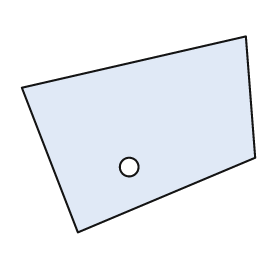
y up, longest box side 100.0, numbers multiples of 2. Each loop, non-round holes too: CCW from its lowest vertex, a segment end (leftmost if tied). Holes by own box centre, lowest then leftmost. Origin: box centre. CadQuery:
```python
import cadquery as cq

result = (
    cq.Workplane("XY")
    .moveTo(-26.0, -42.0)
    .lineTo(50.0, -10.0)
    .lineTo(46.0, 42.0)
    .lineTo(-50.0, 20.0)
    .close()
    .moveTo(-4.0, -14.0)
    .circle(4.0)
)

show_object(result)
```